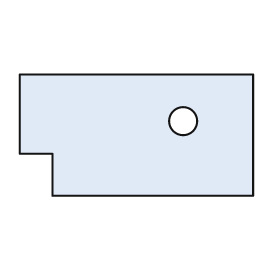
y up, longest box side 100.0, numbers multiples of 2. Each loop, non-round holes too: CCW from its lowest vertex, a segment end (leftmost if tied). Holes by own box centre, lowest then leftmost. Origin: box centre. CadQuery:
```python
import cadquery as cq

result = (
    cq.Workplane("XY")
    .moveTo(-36.0, -26.0)
    .lineTo(50.0, -26.0)
    .lineTo(50.0, 26.0)
    .lineTo(-50.0, 26.0)
    .lineTo(-50.0, -8.0)
    .lineTo(-36.0, -8.0)
    .close()
    .moveTo(20.0, 6.0)
    .circle(6.0)
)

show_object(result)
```